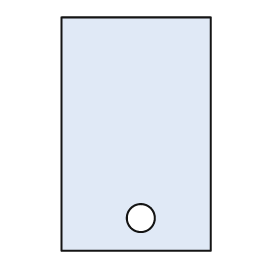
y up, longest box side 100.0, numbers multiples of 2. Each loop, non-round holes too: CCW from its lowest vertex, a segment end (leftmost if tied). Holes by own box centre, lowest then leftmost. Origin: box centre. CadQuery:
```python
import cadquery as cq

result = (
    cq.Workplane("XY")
    .moveTo(-32.0, -50.0)
    .lineTo(32.0, -50.0)
    .lineTo(32.0, 50.0)
    .lineTo(-32.0, 50.0)
    .close()
    .moveTo(2.0, -36.0)
    .circle(6.0)
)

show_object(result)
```